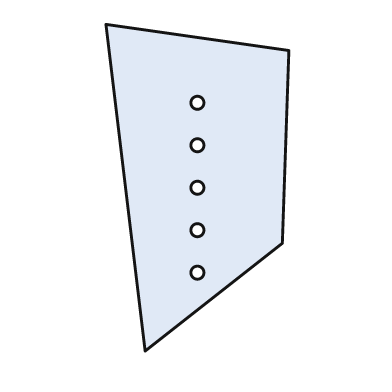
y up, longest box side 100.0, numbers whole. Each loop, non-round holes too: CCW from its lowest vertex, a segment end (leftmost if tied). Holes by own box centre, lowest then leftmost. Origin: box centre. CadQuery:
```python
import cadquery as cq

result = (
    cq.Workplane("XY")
    .moveTo(-16.0, -50.0)
    .lineTo(26.0, -17.0)
    .lineTo(28.0, 42.0)
    .lineTo(-28.0, 50.0)
    .close()
    .moveTo(0.0, -26.0)
    .circle(2.0)
    .moveTo(0.0, -13.0)
    .circle(2.0)
    .moveTo(0.0, 0.0)
    .circle(2.0)
    .moveTo(0.0, 13.0)
    .circle(2.0)
    .moveTo(0.0, 26.0)
    .circle(2.0)
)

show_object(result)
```